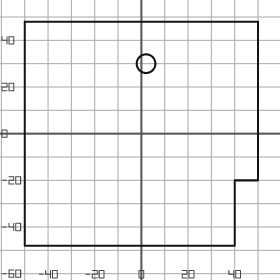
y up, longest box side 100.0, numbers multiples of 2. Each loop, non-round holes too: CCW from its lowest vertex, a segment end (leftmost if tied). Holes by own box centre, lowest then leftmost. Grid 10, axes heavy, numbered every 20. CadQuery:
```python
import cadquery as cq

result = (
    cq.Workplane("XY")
    .moveTo(-50.0, -48.0)
    .lineTo(40.0, -48.0)
    .lineTo(40.0, -20.0)
    .lineTo(50.0, -20.0)
    .lineTo(50.0, 48.0)
    .lineTo(-50.0, 48.0)
    .close()
    .moveTo(2.0, 30.0)
    .circle(4.0)
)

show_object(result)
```